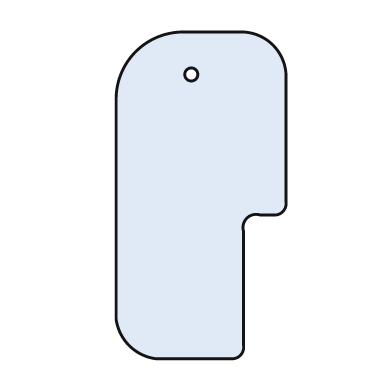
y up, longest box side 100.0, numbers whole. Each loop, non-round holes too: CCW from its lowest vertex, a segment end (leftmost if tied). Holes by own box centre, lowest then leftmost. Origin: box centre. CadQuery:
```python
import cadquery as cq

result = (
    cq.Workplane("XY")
    .moveTo(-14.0, -50.0)
    .lineTo(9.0, -50.0)
    .threePointArc((12.0, -49.0), (13.0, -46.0))
    .lineTo(13.0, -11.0)
    .threePointArc((14.0, -7.0), (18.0, -6.0))
    .lineTo(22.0, -6.0)
    .threePointArc((25.0, -5.0), (26.0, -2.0))
    .lineTo(26.0, 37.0)
    .threePointArc((22.0, 46.0), (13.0, 50.0))
    .lineTo(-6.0, 50.0)
    .threePointArc((-20.0, 44.0), (-26.0, 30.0))
    .lineTo(-26.0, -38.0)
    .threePointArc((-22.0, -46.0), (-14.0, -50.0))
    .close()
    .moveTo(-3.0, 37.0)
    .circle(2.0)
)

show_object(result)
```